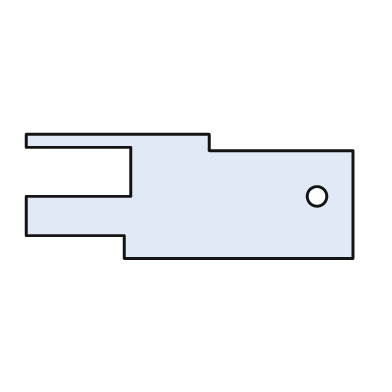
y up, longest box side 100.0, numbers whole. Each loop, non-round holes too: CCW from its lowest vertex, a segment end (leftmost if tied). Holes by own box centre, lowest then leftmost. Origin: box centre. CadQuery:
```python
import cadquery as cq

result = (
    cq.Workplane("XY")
    .moveTo(-20.0, -19.0)
    .lineTo(50.0, -19.0)
    .lineTo(50.0, 14.0)
    .lineTo(6.0, 14.0)
    .lineTo(6.0, 19.0)
    .lineTo(-50.0, 19.0)
    .lineTo(-50.0, 15.0)
    .lineTo(-18.0, 15.0)
    .lineTo(-18.0, 0.0)
    .lineTo(-50.0, 0.0)
    .lineTo(-50.0, -12.0)
    .lineTo(-20.0, -12.0)
    .close()
    .moveTo(39.0, 0.0)
    .circle(3.0)
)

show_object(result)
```